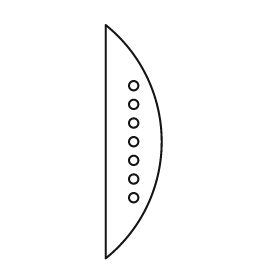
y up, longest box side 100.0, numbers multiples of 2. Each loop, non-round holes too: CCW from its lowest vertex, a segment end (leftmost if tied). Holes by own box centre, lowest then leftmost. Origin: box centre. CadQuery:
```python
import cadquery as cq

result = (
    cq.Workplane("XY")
    .moveTo(-12.0, -50.0)
    .threePointArc((12.0, 0.0), (-12.0, 50.0))
    .close()
    .moveTo(0.0, -24.0)
    .circle(2.0)
    .moveTo(0.0, -16.0)
    .circle(2.0)
    .moveTo(0.0, -8.0)
    .circle(2.0)
    .moveTo(0.0, 0.0)
    .circle(2.0)
    .moveTo(0.0, 8.0)
    .circle(2.0)
    .moveTo(0.0, 16.0)
    .circle(2.0)
    .moveTo(0.0, 24.0)
    .circle(2.0)
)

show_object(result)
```